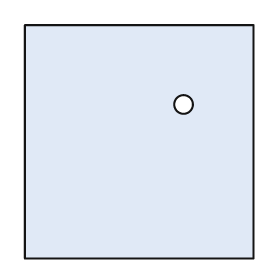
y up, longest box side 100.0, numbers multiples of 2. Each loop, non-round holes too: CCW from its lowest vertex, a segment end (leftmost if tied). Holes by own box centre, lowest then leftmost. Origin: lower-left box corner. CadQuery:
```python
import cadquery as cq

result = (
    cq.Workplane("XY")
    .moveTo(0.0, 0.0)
    .lineTo(98.0, 0.0)
    .lineTo(98.0, 100.0)
    .lineTo(0.0, 100.0)
    .close()
    .moveTo(68.0, 66.0)
    .circle(4.0)
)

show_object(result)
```